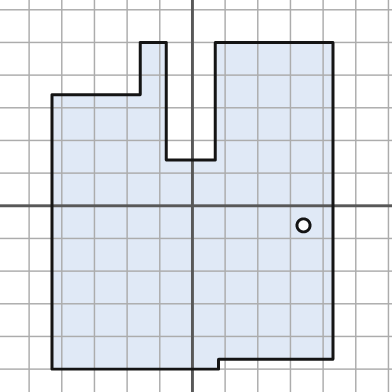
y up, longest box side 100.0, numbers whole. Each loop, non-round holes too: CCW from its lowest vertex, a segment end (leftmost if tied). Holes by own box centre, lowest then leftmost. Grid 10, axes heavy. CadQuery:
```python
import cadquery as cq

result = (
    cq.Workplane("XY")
    .moveTo(-43.0, -50.0)
    .lineTo(8.0, -50.0)
    .lineTo(8.0, -47.0)
    .lineTo(43.0, -47.0)
    .lineTo(43.0, 50.0)
    .lineTo(7.0, 50.0)
    .lineTo(7.0, 14.0)
    .lineTo(-8.0, 14.0)
    .lineTo(-8.0, 50.0)
    .lineTo(-16.0, 50.0)
    .lineTo(-16.0, 34.0)
    .lineTo(-43.0, 34.0)
    .close()
    .moveTo(34.0, -6.0)
    .circle(2.0)
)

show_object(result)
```